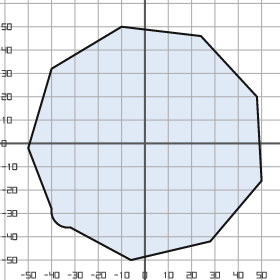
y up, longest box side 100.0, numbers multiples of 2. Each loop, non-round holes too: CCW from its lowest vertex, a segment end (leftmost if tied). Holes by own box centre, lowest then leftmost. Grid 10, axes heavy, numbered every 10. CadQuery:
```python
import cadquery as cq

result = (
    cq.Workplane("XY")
    .moveTo(-6.0, -50.0)
    .lineTo(28.0, -42.0)
    .lineTo(50.0, -16.0)
    .lineTo(48.0, 20.0)
    .lineTo(24.0, 46.0)
    .lineTo(-10.0, 50.0)
    .lineTo(-40.0, 32.0)
    .lineTo(-50.0, -2.0)
    .lineTo(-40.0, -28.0)
    .threePointArc((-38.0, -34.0), (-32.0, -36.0))
    .close()
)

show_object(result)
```